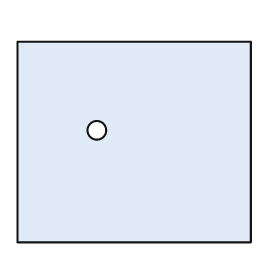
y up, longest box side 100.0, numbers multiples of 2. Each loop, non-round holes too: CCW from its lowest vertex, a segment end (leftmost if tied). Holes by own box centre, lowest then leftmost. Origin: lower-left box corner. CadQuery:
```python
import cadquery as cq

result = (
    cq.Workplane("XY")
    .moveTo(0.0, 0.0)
    .lineTo(100.0, 0.0)
    .lineTo(100.0, 86.0)
    .lineTo(0.0, 86.0)
    .close()
    .moveTo(34.0, 48.0)
    .circle(4.0)
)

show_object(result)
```